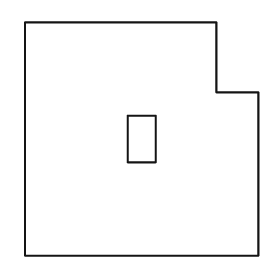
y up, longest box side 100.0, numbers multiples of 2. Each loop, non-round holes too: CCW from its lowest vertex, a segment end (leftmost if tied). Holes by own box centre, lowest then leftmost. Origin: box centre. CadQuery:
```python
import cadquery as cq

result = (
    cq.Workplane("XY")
    .moveTo(-50.0, -50.0)
    .lineTo(50.0, -50.0)
    .lineTo(50.0, 20.0)
    .lineTo(32.0, 20.0)
    .lineTo(32.0, 50.0)
    .lineTo(-50.0, 50.0)
    .close()
    .moveTo(-6.0, -10.0)
    .lineTo(6.0, -10.0)
    .lineTo(6.0, 10.0)
    .lineTo(-6.0, 10.0)
    .close()
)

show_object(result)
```